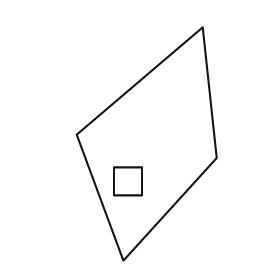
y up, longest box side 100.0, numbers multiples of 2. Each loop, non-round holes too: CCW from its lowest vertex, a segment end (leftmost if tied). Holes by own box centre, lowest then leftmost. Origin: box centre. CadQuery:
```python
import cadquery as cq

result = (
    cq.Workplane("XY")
    .moveTo(-10.0, -50.0)
    .lineTo(30.0, -6.0)
    .lineTo(24.0, 50.0)
    .lineTo(-30.0, 4.0)
    .close()
    .moveTo(-14.0, -22.0)
    .lineTo(-2.0, -22.0)
    .lineTo(-2.0, -10.0)
    .lineTo(-14.0, -10.0)
    .close()
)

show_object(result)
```